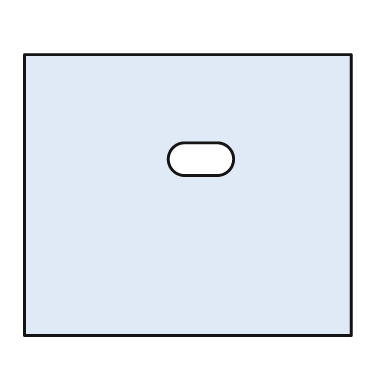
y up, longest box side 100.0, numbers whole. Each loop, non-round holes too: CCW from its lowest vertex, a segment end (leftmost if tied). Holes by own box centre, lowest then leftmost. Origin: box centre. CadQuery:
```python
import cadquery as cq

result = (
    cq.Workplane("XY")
    .moveTo(-50.0, -43.0)
    .lineTo(50.0, -43.0)
    .lineTo(50.0, 43.0)
    .lineTo(-50.0, 43.0)
    .close()
    .moveTo(-1.0, 6.0)
    .lineTo(9.0, 6.0)
    .threePointArc((14.0, 11.0), (9.0, 16.0))
    .lineTo(-1.0, 16.0)
    .threePointArc((-6.0, 11.0), (-1.0, 6.0))
    .close()
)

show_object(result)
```